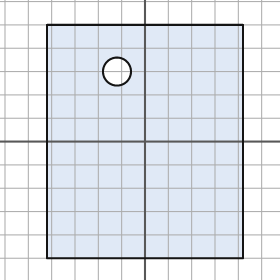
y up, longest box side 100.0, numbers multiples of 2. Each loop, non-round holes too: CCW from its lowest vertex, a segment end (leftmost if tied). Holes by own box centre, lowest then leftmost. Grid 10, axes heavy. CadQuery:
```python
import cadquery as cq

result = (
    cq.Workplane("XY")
    .moveTo(-42.0, -50.0)
    .lineTo(42.0, -50.0)
    .lineTo(42.0, 50.0)
    .lineTo(-42.0, 50.0)
    .close()
    .moveTo(-12.0, 30.0)
    .circle(6.0)
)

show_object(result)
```